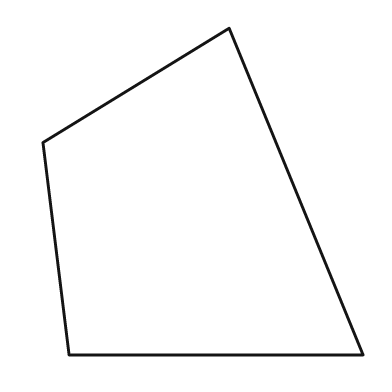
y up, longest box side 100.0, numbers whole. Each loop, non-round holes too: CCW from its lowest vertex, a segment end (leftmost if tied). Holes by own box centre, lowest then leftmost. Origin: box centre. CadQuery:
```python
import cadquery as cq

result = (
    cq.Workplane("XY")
    .moveTo(-41.0, -50.0)
    .lineTo(49.0, -50.0)
    .lineTo(8.0, 50.0)
    .lineTo(-49.0, 15.0)
    .close()
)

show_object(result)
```